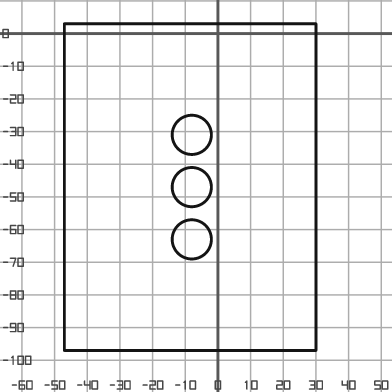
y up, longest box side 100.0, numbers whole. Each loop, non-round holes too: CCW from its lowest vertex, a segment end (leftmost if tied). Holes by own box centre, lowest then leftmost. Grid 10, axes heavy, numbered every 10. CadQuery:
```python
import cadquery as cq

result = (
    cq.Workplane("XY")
    .moveTo(-47.0, -97.0)
    .lineTo(30.0, -97.0)
    .lineTo(30.0, 3.0)
    .lineTo(-47.0, 3.0)
    .close()
    .moveTo(-8.0, -63.0)
    .circle(6.0)
    .moveTo(-8.0, -47.0)
    .circle(6.0)
    .moveTo(-8.0, -31.0)
    .circle(6.0)
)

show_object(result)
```